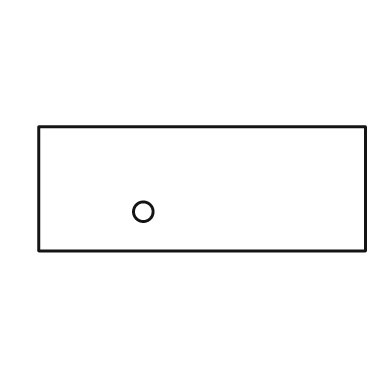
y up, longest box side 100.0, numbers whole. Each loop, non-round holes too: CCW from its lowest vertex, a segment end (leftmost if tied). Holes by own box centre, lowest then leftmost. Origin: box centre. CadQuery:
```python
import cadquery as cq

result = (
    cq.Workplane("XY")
    .moveTo(-50.0, -19.0)
    .lineTo(50.0, -19.0)
    .lineTo(50.0, 19.0)
    .lineTo(-50.0, 19.0)
    .close()
    .moveTo(-18.0, -7.0)
    .circle(3.0)
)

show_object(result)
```